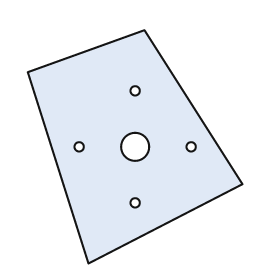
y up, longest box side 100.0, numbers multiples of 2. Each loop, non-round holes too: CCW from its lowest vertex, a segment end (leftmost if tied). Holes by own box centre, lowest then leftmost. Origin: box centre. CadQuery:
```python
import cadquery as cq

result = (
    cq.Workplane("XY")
    .moveTo(-20.0, -50.0)
    .lineTo(46.0, -16.0)
    .lineTo(4.0, 50.0)
    .lineTo(-46.0, 32.0)
    .close()
    .moveTo(0.0, -24.0)
    .circle(2.0)
    .moveTo(-24.0, 0.0)
    .circle(2.0)
    .moveTo(0.0, 0.0)
    .circle(6.0)
    .moveTo(24.0, 0.0)
    .circle(2.0)
    .moveTo(0.0, 24.0)
    .circle(2.0)
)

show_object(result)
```